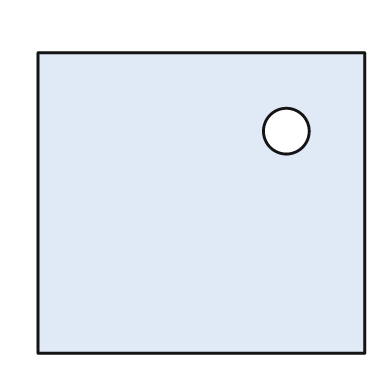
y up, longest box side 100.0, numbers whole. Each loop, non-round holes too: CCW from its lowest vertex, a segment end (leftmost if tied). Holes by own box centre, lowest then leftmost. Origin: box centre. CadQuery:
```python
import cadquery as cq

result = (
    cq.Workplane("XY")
    .moveTo(-50.0, -46.0)
    .lineTo(50.0, -46.0)
    .lineTo(50.0, 46.0)
    .lineTo(-50.0, 46.0)
    .close()
    .moveTo(26.0, 22.0)
    .circle(7.0)
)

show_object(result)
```